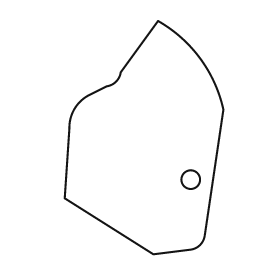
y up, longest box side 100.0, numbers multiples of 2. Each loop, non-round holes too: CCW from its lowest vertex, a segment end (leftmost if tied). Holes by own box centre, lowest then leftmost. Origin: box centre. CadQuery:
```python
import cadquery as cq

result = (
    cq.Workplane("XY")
    .moveTo(4.0, -50.0)
    .lineTo(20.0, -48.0)
    .threePointArc((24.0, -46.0), (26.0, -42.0))
    .lineTo(34.0, 12.0)
    .threePointArc((24.0, 34.0), (6.0, 50.0))
    .lineTo(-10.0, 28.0)
    .threePointArc((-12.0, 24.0), (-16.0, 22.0))
    .lineTo(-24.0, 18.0)
    .threePointArc((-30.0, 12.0), (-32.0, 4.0))
    .lineTo(-34.0, -26.0)
    .close()
    .moveTo(20.0, -18.0)
    .circle(4.0)
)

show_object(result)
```